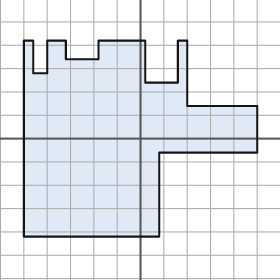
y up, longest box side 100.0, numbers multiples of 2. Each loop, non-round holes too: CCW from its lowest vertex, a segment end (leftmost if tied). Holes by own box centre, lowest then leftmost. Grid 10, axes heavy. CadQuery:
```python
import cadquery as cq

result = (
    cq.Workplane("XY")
    .moveTo(-50.0, -42.0)
    .lineTo(8.0, -42.0)
    .lineTo(8.0, -6.0)
    .lineTo(50.0, -6.0)
    .lineTo(50.0, 14.0)
    .lineTo(20.0, 14.0)
    .lineTo(20.0, 42.0)
    .lineTo(16.0, 42.0)
    .lineTo(16.0, 24.0)
    .lineTo(2.0, 24.0)
    .lineTo(2.0, 42.0)
    .lineTo(-18.0, 42.0)
    .lineTo(-18.0, 34.0)
    .lineTo(-32.0, 34.0)
    .lineTo(-32.0, 42.0)
    .lineTo(-40.0, 42.0)
    .lineTo(-40.0, 28.0)
    .lineTo(-46.0, 28.0)
    .lineTo(-46.0, 42.0)
    .lineTo(-50.0, 42.0)
    .close()
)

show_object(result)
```